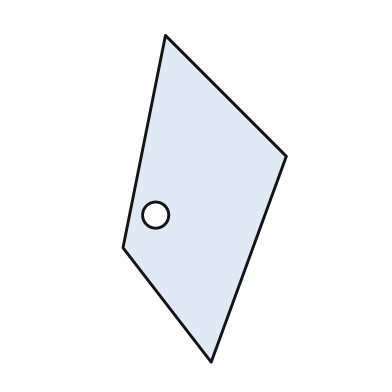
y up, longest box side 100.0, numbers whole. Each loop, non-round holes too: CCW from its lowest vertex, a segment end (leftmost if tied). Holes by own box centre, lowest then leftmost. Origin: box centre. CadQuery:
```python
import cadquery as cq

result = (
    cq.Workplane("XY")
    .moveTo(2.0, -50.0)
    .lineTo(25.0, 13.0)
    .lineTo(-12.0, 50.0)
    .lineTo(-25.0, -15.0)
    .close()
    .moveTo(-15.0, -5.0)
    .circle(4.0)
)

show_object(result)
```